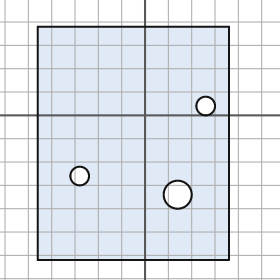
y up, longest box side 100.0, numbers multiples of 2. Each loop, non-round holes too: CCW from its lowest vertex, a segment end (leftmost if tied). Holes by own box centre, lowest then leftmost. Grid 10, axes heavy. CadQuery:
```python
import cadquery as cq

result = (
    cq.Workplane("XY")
    .moveTo(-46.0, -62.0)
    .lineTo(36.0, -62.0)
    .lineTo(36.0, 38.0)
    .lineTo(-46.0, 38.0)
    .close()
    .moveTo(14.0, -34.0)
    .circle(6.0)
    .moveTo(-28.0, -26.0)
    .circle(4.0)
    .moveTo(26.0, 4.0)
    .circle(4.0)
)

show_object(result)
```